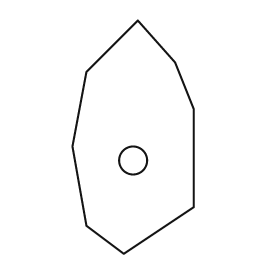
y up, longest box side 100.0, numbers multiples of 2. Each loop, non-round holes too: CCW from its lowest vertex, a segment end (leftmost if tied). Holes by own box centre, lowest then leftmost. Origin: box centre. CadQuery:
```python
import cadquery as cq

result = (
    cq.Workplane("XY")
    .moveTo(-4.0, -50.0)
    .lineTo(26.0, -30.0)
    .lineTo(26.0, 12.0)
    .lineTo(18.0, 32.0)
    .lineTo(2.0, 50.0)
    .lineTo(-20.0, 28.0)
    .lineTo(-26.0, -4.0)
    .lineTo(-20.0, -38.0)
    .close()
    .moveTo(0.0, -10.0)
    .circle(6.0)
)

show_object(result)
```